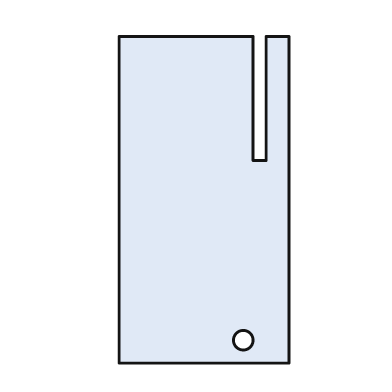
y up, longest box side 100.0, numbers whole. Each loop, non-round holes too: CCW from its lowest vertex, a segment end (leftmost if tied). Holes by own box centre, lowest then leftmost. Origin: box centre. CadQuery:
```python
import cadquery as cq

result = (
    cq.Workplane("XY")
    .moveTo(-26.0, -50.0)
    .lineTo(26.0, -50.0)
    .lineTo(26.0, 50.0)
    .lineTo(19.0, 50.0)
    .lineTo(19.0, 12.0)
    .lineTo(15.0, 12.0)
    .lineTo(15.0, 50.0)
    .lineTo(-26.0, 50.0)
    .close()
    .moveTo(12.0, -43.0)
    .circle(3.0)
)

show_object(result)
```